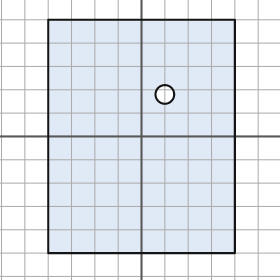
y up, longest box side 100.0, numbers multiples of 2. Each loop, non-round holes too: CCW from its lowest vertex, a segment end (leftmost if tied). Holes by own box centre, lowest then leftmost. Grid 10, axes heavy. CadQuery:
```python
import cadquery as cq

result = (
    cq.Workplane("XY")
    .moveTo(-40.0, -50.0)
    .lineTo(40.0, -50.0)
    .lineTo(40.0, 50.0)
    .lineTo(-40.0, 50.0)
    .close()
    .moveTo(10.0, 18.0)
    .circle(4.0)
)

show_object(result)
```